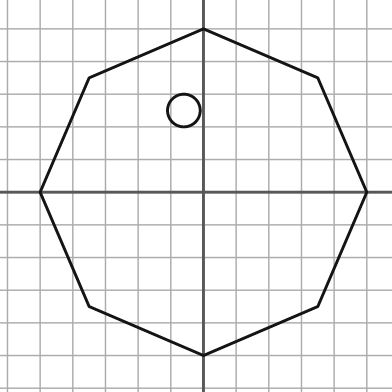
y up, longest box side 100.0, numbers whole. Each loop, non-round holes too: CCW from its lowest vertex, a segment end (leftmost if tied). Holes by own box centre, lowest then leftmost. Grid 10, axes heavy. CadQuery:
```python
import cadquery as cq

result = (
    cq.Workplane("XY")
    .moveTo(0.0, -50.0)
    .lineTo(35.0, -35.0)
    .lineTo(50.0, 0.0)
    .lineTo(35.0, 35.0)
    .lineTo(0.0, 50.0)
    .lineTo(-35.0, 35.0)
    .lineTo(-50.0, 0.0)
    .lineTo(-35.0, -35.0)
    .close()
    .moveTo(-6.0, 25.0)
    .circle(5.0)
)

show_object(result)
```